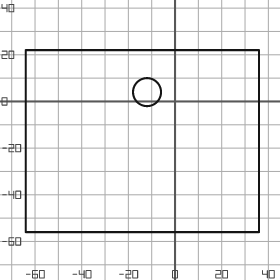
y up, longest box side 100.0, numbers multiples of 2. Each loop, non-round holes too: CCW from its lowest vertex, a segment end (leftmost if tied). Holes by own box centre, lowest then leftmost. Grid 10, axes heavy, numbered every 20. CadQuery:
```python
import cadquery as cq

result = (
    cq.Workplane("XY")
    .moveTo(-64.0, -56.0)
    .lineTo(36.0, -56.0)
    .lineTo(36.0, 22.0)
    .lineTo(-64.0, 22.0)
    .close()
    .moveTo(-12.0, 4.0)
    .circle(6.0)
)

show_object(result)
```